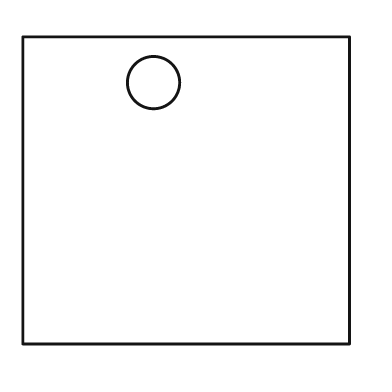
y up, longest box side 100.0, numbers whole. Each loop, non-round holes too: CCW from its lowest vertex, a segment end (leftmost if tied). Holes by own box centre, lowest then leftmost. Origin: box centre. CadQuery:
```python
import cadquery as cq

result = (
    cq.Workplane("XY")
    .moveTo(-50.0, -47.0)
    .lineTo(50.0, -47.0)
    .lineTo(50.0, 47.0)
    .lineTo(-50.0, 47.0)
    .close()
    .moveTo(-10.0, 33.0)
    .circle(8.0)
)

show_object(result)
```